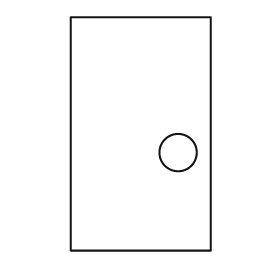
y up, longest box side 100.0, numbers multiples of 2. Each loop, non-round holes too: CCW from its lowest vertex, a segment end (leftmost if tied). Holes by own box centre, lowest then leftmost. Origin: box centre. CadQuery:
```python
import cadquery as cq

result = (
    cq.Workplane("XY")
    .moveTo(-30.0, -50.0)
    .lineTo(30.0, -50.0)
    .lineTo(30.0, 50.0)
    .lineTo(-30.0, 50.0)
    .close()
    .moveTo(16.0, -8.0)
    .circle(8.0)
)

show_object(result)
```